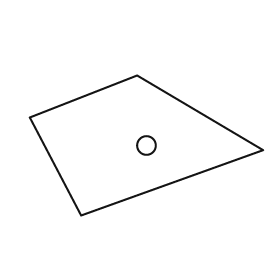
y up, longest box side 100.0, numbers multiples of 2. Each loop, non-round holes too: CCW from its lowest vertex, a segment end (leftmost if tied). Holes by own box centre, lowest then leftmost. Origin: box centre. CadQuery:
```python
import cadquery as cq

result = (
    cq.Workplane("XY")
    .moveTo(-28.0, -30.0)
    .lineTo(50.0, -2.0)
    .lineTo(-4.0, 30.0)
    .lineTo(-50.0, 12.0)
    .close()
    .moveTo(0.0, 0.0)
    .circle(4.0)
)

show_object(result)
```